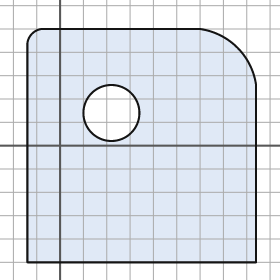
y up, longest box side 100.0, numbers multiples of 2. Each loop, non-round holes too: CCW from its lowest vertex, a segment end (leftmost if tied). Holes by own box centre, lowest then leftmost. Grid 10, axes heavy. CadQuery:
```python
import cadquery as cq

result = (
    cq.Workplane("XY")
    .moveTo(-14.0, -50.0)
    .lineTo(84.0, -50.0)
    .lineTo(84.0, 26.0)
    .threePointArc((76.0, 42.0), (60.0, 50.0))
    .lineTo(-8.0, 50.0)
    .threePointArc((-12.0, 48.0), (-14.0, 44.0))
    .close()
    .moveTo(22.0, 14.0)
    .circle(12.0)
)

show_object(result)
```